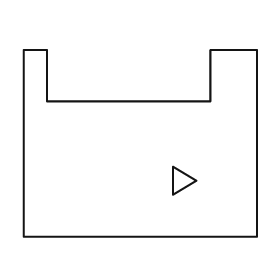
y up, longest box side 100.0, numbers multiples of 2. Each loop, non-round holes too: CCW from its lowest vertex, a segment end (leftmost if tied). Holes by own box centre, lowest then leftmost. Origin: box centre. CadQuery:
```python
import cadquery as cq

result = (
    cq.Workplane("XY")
    .moveTo(-50.0, -40.0)
    .lineTo(50.0, -40.0)
    .lineTo(50.0, 40.0)
    .lineTo(30.0, 40.0)
    .lineTo(30.0, 18.0)
    .lineTo(-40.0, 18.0)
    .lineTo(-40.0, 40.0)
    .lineTo(-50.0, 40.0)
    .close()
    .moveTo(14.0, -22.0)
    .lineTo(24.0, -16.0)
    .lineTo(14.0, -10.0)
    .close()
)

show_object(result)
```